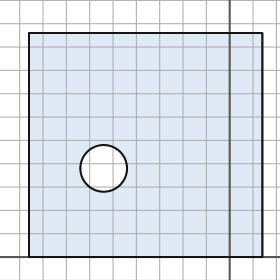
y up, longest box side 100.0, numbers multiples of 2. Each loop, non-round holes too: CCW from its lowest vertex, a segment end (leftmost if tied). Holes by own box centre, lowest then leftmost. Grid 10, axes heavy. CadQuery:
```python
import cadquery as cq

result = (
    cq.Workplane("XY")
    .moveTo(-86.0, 0.0)
    .lineTo(14.0, 0.0)
    .lineTo(14.0, 96.0)
    .lineTo(-86.0, 96.0)
    .close()
    .moveTo(-54.0, 38.0)
    .circle(10.0)
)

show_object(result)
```